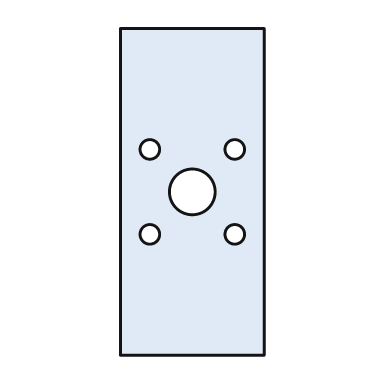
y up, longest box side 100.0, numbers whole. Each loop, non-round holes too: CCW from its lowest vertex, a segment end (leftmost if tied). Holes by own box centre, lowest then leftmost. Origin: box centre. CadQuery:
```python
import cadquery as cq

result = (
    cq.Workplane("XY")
    .moveTo(-22.0, -50.0)
    .lineTo(22.0, -50.0)
    .lineTo(22.0, 50.0)
    .lineTo(-22.0, 50.0)
    .close()
    .moveTo(-13.0, -13.0)
    .circle(3.0)
    .moveTo(13.0, -13.0)
    .circle(3.0)
    .moveTo(0.0, 0.0)
    .circle(7.0)
    .moveTo(-13.0, 13.0)
    .circle(3.0)
    .moveTo(13.0, 13.0)
    .circle(3.0)
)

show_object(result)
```